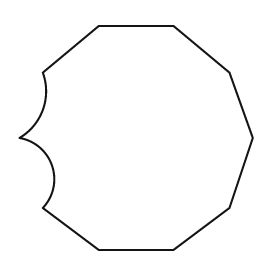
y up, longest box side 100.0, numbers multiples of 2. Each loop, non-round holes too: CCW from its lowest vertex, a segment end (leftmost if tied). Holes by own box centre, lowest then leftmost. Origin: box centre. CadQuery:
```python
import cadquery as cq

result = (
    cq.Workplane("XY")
    .moveTo(-16.0, -48.0)
    .lineTo(16.0, -48.0)
    .lineTo(40.0, -30.0)
    .lineTo(50.0, 0.0)
    .lineTo(40.0, 28.0)
    .lineTo(16.0, 48.0)
    .lineTo(-16.0, 48.0)
    .lineTo(-40.0, 28.0)
    .threePointArc((-40.0, 12.0), (-50.0, 0.0))
    .threePointArc((-36.0, -12.0), (-40.0, -30.0))
    .close()
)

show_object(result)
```